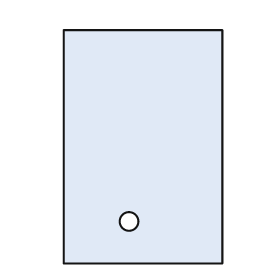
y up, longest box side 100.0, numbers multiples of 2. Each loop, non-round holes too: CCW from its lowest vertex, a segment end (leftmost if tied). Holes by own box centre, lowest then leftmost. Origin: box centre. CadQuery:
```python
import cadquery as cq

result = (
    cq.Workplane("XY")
    .moveTo(-34.0, -50.0)
    .lineTo(34.0, -50.0)
    .lineTo(34.0, 50.0)
    .lineTo(-34.0, 50.0)
    .close()
    .moveTo(-6.0, -32.0)
    .circle(4.0)
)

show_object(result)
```